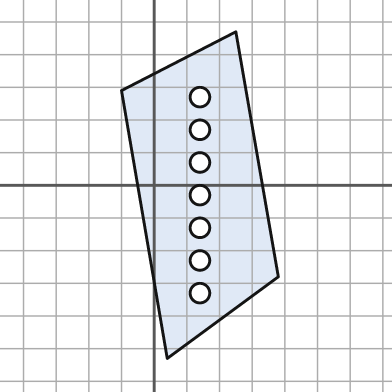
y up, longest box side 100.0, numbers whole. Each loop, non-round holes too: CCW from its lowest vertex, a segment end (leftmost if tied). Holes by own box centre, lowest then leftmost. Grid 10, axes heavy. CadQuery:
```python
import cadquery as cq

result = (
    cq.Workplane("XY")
    .moveTo(4.0, -53.0)
    .lineTo(38.0, -28.0)
    .lineTo(25.0, 47.0)
    .lineTo(-10.0, 29.0)
    .close()
    .moveTo(14.0, -33.0)
    .circle(3.0)
    .moveTo(14.0, -23.0)
    .circle(3.0)
    .moveTo(14.0, -13.0)
    .circle(3.0)
    .moveTo(14.0, -3.0)
    .circle(3.0)
    .moveTo(14.0, 7.0)
    .circle(3.0)
    .moveTo(14.0, 17.0)
    .circle(3.0)
    .moveTo(14.0, 27.0)
    .circle(3.0)
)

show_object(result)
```